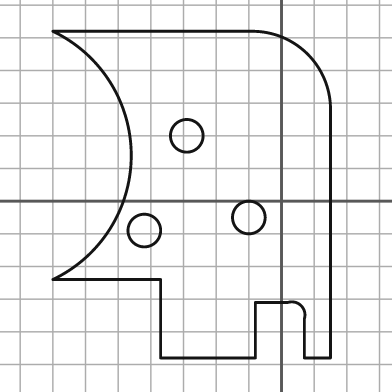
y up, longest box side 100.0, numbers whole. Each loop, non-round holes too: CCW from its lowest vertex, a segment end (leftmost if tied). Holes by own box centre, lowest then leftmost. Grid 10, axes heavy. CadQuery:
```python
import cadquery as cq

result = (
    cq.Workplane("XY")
    .moveTo(-37.0, -48.0)
    .lineTo(-8.0, -48.0)
    .lineTo(-8.0, -31.0)
    .lineTo(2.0, -31.0)
    .threePointArc((6.0, -32.0), (7.0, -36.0))
    .lineTo(7.0, -48.0)
    .lineTo(15.0, -48.0)
    .lineTo(15.0, 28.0)
    .threePointArc((8.0, 45.0), (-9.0, 52.0))
    .lineTo(-70.0, 52.0)
    .threePointArc((-46.0, 14.0), (-70.0, -24.0))
    .lineTo(-37.0, -24.0)
    .close()
    .moveTo(-42.0, -9.0)
    .circle(5.0)
    .moveTo(-10.0, -5.0)
    .circle(5.0)
    .moveTo(-29.0, 20.0)
    .circle(5.0)
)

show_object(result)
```